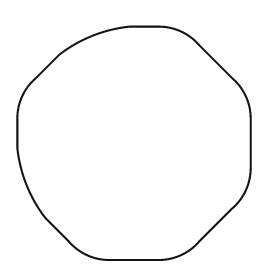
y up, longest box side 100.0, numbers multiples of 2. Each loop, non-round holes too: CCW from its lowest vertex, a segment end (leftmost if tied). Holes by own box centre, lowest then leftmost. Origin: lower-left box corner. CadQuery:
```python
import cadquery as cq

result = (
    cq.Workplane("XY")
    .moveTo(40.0, 0.0)
    .lineTo(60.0, 0.0)
    .threePointArc((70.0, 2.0), (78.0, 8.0))
    .lineTo(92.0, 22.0)
    .threePointArc((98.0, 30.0), (100.0, 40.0))
    .lineTo(100.0, 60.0)
    .threePointArc((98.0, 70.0), (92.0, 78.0))
    .lineTo(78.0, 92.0)
    .threePointArc((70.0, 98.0), (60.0, 100.0))
    .lineTo(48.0, 100.0)
    .threePointArc((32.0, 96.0), (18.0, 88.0))
    .lineTo(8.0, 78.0)
    .threePointArc((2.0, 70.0), (0.0, 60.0))
    .lineTo(0.0, 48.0)
    .threePointArc((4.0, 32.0), (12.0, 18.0))
    .lineTo(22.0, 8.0)
    .threePointArc((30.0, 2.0), (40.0, 0.0))
    .close()
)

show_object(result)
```